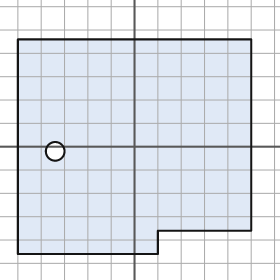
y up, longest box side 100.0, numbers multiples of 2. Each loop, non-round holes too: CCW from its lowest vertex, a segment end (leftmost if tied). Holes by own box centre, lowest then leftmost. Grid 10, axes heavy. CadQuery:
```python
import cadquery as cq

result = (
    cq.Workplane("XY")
    .moveTo(-50.0, -46.0)
    .lineTo(10.0, -46.0)
    .lineTo(10.0, -36.0)
    .lineTo(50.0, -36.0)
    .lineTo(50.0, 46.0)
    .lineTo(-50.0, 46.0)
    .close()
    .moveTo(-34.0, -2.0)
    .circle(4.0)
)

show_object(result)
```